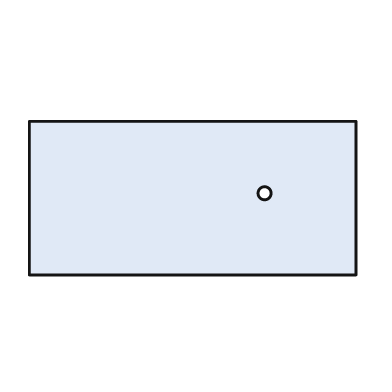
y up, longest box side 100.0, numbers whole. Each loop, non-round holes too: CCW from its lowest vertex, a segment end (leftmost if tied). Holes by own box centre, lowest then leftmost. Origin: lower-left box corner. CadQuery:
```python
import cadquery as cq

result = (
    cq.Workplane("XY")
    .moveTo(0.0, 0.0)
    .lineTo(100.0, 0.0)
    .lineTo(100.0, 47.0)
    .lineTo(0.0, 47.0)
    .close()
    .moveTo(72.0, 25.0)
    .circle(2.0)
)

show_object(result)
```